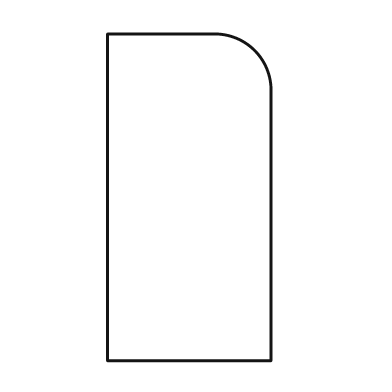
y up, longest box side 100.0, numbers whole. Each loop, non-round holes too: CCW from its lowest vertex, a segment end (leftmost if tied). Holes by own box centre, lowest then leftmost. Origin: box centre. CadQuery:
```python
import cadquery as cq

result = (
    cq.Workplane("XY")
    .moveTo(-25.0, -50.0)
    .lineTo(25.0, -50.0)
    .lineTo(25.0, 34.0)
    .threePointArc((20.0, 45.0), (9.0, 50.0))
    .lineTo(-25.0, 50.0)
    .close()
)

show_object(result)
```